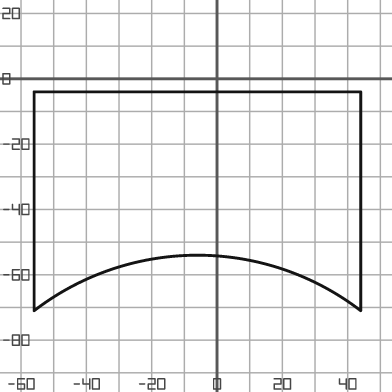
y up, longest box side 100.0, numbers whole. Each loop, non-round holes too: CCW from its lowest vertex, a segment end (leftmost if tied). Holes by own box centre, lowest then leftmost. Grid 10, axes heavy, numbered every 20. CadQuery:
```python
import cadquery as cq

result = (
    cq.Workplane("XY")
    .moveTo(-56.0, -71.0)
    .threePointArc((-6.0, -54.0), (44.0, -71.0))
    .lineTo(44.0, -4.0)
    .lineTo(-56.0, -4.0)
    .close()
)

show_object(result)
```